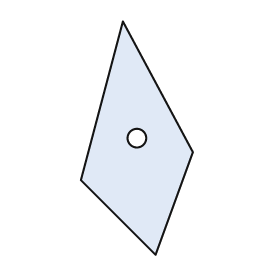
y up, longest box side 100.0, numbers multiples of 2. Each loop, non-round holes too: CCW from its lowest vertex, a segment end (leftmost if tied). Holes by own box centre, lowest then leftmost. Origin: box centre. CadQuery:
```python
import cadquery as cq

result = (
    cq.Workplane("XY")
    .moveTo(8.0, -50.0)
    .lineTo(24.0, -6.0)
    .lineTo(-6.0, 50.0)
    .lineTo(-24.0, -18.0)
    .close()
    .moveTo(0.0, 0.0)
    .circle(4.0)
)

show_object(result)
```